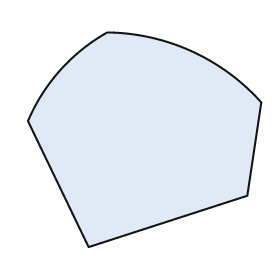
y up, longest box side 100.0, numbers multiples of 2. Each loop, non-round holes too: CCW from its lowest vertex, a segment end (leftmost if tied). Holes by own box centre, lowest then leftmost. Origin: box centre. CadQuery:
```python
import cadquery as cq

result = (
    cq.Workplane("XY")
    .moveTo(-24.0, -46.0)
    .lineTo(44.0, -24.0)
    .lineTo(50.0, 16.0)
    .threePointArc((20.0, 38.0), (-16.0, 46.0))
    .threePointArc((-36.0, 30.0), (-50.0, 8.0))
    .close()
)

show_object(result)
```